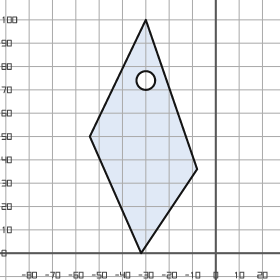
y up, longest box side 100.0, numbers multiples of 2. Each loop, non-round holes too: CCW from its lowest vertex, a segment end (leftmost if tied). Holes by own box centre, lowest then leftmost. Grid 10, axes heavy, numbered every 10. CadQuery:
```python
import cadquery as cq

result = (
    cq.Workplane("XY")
    .moveTo(-32.0, 0.0)
    .lineTo(-8.0, 36.0)
    .lineTo(-30.0, 100.0)
    .lineTo(-54.0, 50.0)
    .close()
    .moveTo(-30.0, 74.0)
    .circle(4.0)
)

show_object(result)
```